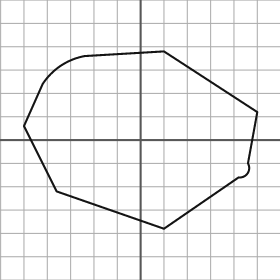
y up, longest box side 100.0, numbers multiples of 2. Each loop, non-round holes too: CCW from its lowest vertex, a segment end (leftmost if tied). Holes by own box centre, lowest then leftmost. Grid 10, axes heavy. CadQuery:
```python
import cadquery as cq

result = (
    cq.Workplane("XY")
    .moveTo(10.0, -38.0)
    .lineTo(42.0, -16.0)
    .threePointArc((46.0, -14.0), (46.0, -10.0))
    .lineTo(50.0, 12.0)
    .lineTo(10.0, 38.0)
    .lineTo(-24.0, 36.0)
    .threePointArc((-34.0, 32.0), (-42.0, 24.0))
    .lineTo(-50.0, 6.0)
    .lineTo(-36.0, -22.0)
    .close()
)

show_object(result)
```